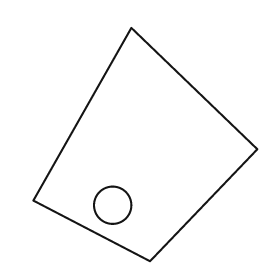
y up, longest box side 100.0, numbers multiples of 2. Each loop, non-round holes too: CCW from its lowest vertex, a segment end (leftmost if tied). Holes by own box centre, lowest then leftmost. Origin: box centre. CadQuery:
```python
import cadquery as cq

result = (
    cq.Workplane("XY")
    .moveTo(2.0, -50.0)
    .lineTo(48.0, -2.0)
    .lineTo(-6.0, 50.0)
    .lineTo(-48.0, -24.0)
    .close()
    .moveTo(-14.0, -26.0)
    .circle(8.0)
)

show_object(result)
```